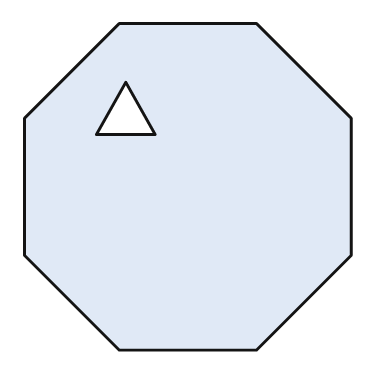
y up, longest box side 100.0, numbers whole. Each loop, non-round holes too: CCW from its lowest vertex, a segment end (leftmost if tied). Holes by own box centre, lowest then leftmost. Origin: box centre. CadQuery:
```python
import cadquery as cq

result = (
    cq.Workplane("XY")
    .moveTo(-21.0, -50.0)
    .lineTo(21.0, -50.0)
    .lineTo(50.0, -21.0)
    .lineTo(50.0, 21.0)
    .lineTo(21.0, 50.0)
    .lineTo(-21.0, 50.0)
    .lineTo(-50.0, 21.0)
    .lineTo(-50.0, -21.0)
    .close()
    .moveTo(-28.0, 16.0)
    .lineTo(-10.0, 16.0)
    .lineTo(-19.0, 32.0)
    .close()
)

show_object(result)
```